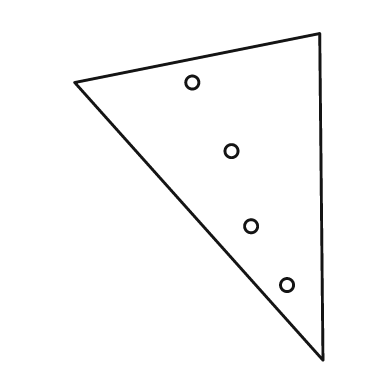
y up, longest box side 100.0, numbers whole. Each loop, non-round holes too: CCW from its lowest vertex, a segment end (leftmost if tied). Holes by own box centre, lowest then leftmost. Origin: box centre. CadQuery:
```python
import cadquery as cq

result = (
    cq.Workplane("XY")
    .moveTo(38.0, -50.0)
    .lineTo(37.0, 50.0)
    .lineTo(-38.0, 35.0)
    .close()
    .moveTo(27.0, -27.0)
    .circle(2.0)
    .moveTo(16.0, -9.0)
    .circle(2.0)
    .moveTo(10.0, 14.0)
    .circle(2.0)
    .moveTo(-2.0, 35.0)
    .circle(2.0)
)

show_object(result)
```